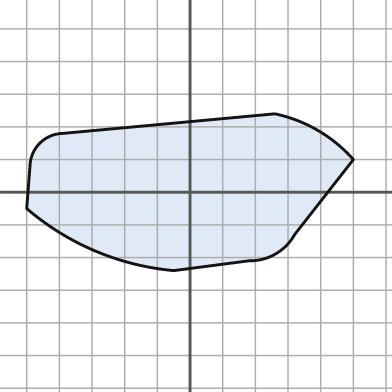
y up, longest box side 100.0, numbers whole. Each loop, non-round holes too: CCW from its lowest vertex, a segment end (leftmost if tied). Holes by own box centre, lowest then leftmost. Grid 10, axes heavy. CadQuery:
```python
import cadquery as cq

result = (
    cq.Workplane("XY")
    .moveTo(-5.0, -24.0)
    .lineTo(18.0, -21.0)
    .threePointArc((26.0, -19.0), (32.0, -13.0))
    .lineTo(50.0, 10.0)
    .threePointArc((39.0, 19.0), (26.0, 24.0))
    .lineTo(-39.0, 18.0)
    .threePointArc((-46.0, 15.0), (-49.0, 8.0))
    .lineTo(-50.0, -5.0)
    .threePointArc((-29.0, -18.0), (-5.0, -24.0))
    .close()
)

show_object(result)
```